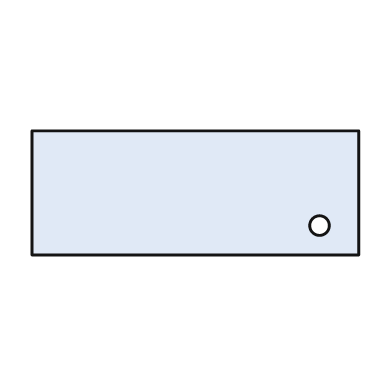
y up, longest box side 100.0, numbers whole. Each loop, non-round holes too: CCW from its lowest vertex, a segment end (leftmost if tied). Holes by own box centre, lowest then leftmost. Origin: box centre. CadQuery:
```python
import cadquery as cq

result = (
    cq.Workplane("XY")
    .moveTo(-50.0, -19.0)
    .lineTo(50.0, -19.0)
    .lineTo(50.0, 19.0)
    .lineTo(-50.0, 19.0)
    .close()
    .moveTo(38.0, -10.0)
    .circle(3.0)
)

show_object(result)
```